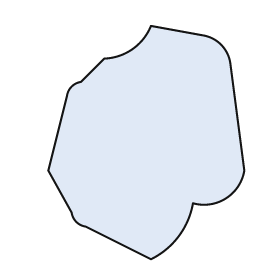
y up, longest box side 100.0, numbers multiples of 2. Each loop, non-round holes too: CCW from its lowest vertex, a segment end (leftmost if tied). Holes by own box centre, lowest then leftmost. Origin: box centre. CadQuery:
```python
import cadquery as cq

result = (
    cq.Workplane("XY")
    .moveTo(2.0, -50.0)
    .threePointArc((14.0, -40.0), (20.0, -26.0))
    .threePointArc((34.0, -24.0), (42.0, -12.0))
    .lineTo(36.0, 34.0)
    .threePointArc((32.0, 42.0), (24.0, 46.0))
    .lineTo(2.0, 50.0)
    .threePointArc((-6.0, 40.0), (-18.0, 36.0))
    .lineTo(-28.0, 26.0)
    .threePointArc((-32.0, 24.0), (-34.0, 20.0))
    .lineTo(-42.0, -12.0)
    .lineTo(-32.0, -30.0)
    .threePointArc((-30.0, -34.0), (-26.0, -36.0))
    .close()
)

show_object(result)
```